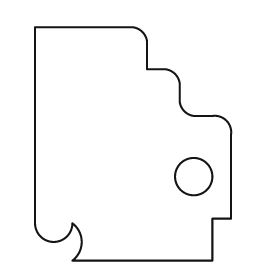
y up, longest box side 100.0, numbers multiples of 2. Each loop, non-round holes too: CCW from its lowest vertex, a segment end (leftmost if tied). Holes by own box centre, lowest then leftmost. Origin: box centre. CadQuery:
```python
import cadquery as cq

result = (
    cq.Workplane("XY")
    .moveTo(-26.0, -50.0)
    .lineTo(34.0, -50.0)
    .lineTo(34.0, -32.0)
    .lineTo(42.0, -32.0)
    .lineTo(42.0, 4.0)
    .threePointArc((40.0, 10.0), (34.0, 12.0))
    .lineTo(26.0, 12.0)
    .threePointArc((22.0, 14.0), (20.0, 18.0))
    .lineTo(20.0, 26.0)
    .threePointArc((18.0, 30.0), (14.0, 32.0))
    .lineTo(6.0, 32.0)
    .lineTo(6.0, 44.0)
    .threePointArc((4.0, 48.0), (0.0, 50.0))
    .lineTo(-42.0, 50.0)
    .lineTo(-42.0, -34.0)
    .threePointArc((-34.0, -42.0), (-26.0, -34.0))
    .threePointArc((-22.0, -42.0), (-26.0, -50.0))
    .close()
    .moveTo(26.0, -14.0)
    .circle(8.0)
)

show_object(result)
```